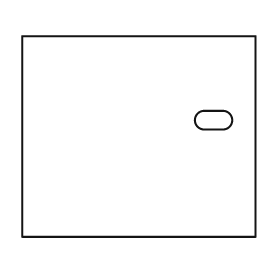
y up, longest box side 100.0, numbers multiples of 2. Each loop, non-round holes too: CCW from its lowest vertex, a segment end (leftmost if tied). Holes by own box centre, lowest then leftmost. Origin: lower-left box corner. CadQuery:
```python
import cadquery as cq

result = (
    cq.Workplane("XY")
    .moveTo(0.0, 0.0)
    .lineTo(100.0, 0.0)
    .lineTo(100.0, 86.0)
    .lineTo(0.0, 86.0)
    .close()
    .moveTo(78.0, 46.0)
    .lineTo(86.0, 46.0)
    .threePointArc((90.0, 50.0), (86.0, 54.0))
    .lineTo(78.0, 54.0)
    .threePointArc((74.0, 50.0), (78.0, 46.0))
    .close()
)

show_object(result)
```